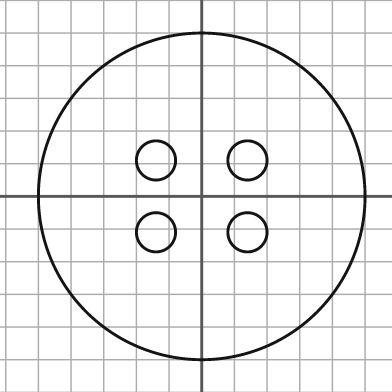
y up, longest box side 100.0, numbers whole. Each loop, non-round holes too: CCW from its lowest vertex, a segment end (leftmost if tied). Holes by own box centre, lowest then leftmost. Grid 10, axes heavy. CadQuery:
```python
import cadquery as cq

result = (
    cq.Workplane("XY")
    .moveTo(0.0, 0.0)
    .circle(50.0)
    .moveTo(-14.0, -11.0)
    .circle(6.0)
    .moveTo(14.0, -11.0)
    .circle(6.0)
    .moveTo(-14.0, 11.0)
    .circle(6.0)
    .moveTo(14.0, 11.0)
    .circle(6.0)
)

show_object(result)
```